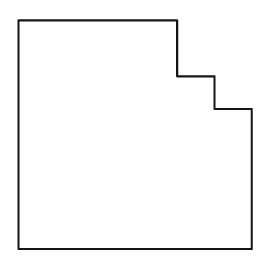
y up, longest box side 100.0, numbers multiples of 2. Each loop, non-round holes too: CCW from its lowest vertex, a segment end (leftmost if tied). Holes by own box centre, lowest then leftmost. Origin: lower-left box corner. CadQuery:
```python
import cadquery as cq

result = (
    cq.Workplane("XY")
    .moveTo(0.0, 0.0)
    .lineTo(100.0, 0.0)
    .lineTo(100.0, 60.0)
    .lineTo(84.0, 60.0)
    .lineTo(84.0, 74.0)
    .lineTo(68.0, 74.0)
    .lineTo(68.0, 98.0)
    .lineTo(0.0, 98.0)
    .close()
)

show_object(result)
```